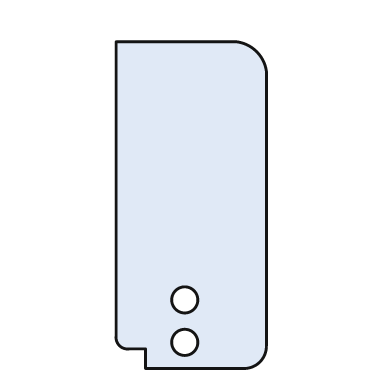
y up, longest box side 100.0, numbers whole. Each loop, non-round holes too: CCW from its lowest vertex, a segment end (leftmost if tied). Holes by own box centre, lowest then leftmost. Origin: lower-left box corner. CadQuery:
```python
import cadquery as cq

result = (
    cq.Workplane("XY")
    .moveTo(9.0, 0.0)
    .lineTo(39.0, 0.0)
    .threePointArc((44.0, 2.0), (46.0, 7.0))
    .lineTo(46.0, 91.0)
    .threePointArc((43.0, 97.0), (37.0, 100.0))
    .lineTo(0.0, 100.0)
    .lineTo(0.0, 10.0)
    .threePointArc((1.0, 7.0), (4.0, 6.0))
    .lineTo(9.0, 6.0)
    .close()
    .moveTo(21.0, 8.0)
    .circle(4.0)
    .moveTo(21.0, 21.0)
    .circle(4.0)
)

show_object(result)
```